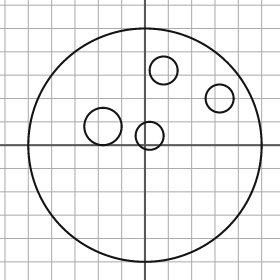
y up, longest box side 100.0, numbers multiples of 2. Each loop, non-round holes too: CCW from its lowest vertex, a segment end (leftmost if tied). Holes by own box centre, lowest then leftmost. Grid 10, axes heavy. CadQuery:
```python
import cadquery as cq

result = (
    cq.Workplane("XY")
    .moveTo(0.0, 0.0)
    .circle(50.0)
    .moveTo(2.0, 4.0)
    .circle(6.0)
    .moveTo(-18.0, 8.0)
    .circle(8.0)
    .moveTo(32.0, 20.0)
    .circle(6.0)
    .moveTo(8.0, 32.0)
    .circle(6.0)
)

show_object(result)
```